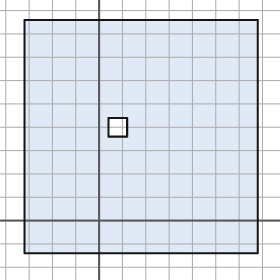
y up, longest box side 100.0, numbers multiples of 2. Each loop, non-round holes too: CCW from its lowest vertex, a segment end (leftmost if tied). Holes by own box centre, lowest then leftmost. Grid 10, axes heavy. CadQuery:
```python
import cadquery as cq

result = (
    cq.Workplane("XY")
    .moveTo(-32.0, -14.0)
    .lineTo(68.0, -14.0)
    .lineTo(68.0, 86.0)
    .lineTo(-32.0, 86.0)
    .close()
    .moveTo(4.0, 36.0)
    .lineTo(12.0, 36.0)
    .lineTo(12.0, 44.0)
    .lineTo(4.0, 44.0)
    .close()
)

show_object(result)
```